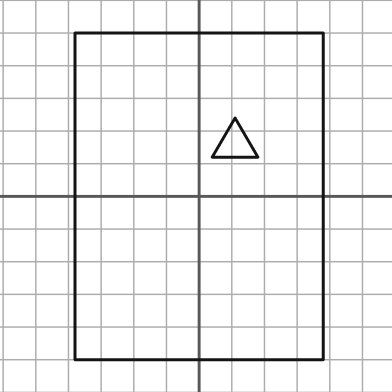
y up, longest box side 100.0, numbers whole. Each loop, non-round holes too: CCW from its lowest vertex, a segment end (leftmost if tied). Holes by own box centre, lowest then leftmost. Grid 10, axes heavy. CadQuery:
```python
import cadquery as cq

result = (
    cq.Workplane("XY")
    .moveTo(-38.0, -50.0)
    .lineTo(38.0, -50.0)
    .lineTo(38.0, 50.0)
    .lineTo(-38.0, 50.0)
    .close()
    .moveTo(4.0, 12.0)
    .lineTo(18.0, 12.0)
    .lineTo(11.0, 24.0)
    .close()
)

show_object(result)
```